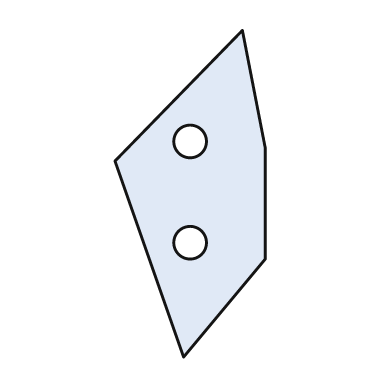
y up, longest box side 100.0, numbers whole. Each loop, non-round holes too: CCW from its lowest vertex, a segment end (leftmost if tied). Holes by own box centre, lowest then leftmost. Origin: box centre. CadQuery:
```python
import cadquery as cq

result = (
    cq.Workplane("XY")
    .moveTo(-2.0, -50.0)
    .lineTo(23.0, -20.0)
    .lineTo(23.0, 14.0)
    .lineTo(16.0, 50.0)
    .lineTo(-23.0, 10.0)
    .close()
    .moveTo(0.0, -15.0)
    .circle(5.0)
    .moveTo(0.0, 16.0)
    .circle(5.0)
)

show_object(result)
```